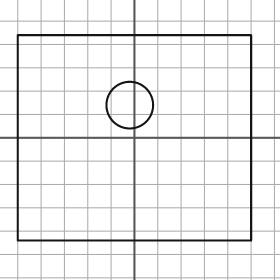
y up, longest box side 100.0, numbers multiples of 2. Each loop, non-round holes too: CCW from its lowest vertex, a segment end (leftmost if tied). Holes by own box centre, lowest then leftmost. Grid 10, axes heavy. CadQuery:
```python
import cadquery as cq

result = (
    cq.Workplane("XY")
    .moveTo(-50.0, -44.0)
    .lineTo(50.0, -44.0)
    .lineTo(50.0, 44.0)
    .lineTo(-50.0, 44.0)
    .close()
    .moveTo(-2.0, 14.0)
    .circle(10.0)
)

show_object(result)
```